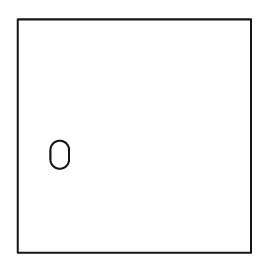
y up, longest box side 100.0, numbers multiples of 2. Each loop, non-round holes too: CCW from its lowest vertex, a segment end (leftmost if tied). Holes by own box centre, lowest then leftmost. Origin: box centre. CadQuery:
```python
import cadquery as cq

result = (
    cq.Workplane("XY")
    .moveTo(-50.0, -50.0)
    .lineTo(50.0, -50.0)
    .lineTo(50.0, 50.0)
    .lineTo(-50.0, 50.0)
    .close()
    .moveTo(-36.0, -10.0)
    .threePointArc((-32.0, -14.0), (-28.0, -10.0))
    .lineTo(-28.0, -6.0)
    .threePointArc((-32.0, -2.0), (-36.0, -6.0))
    .close()
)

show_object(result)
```